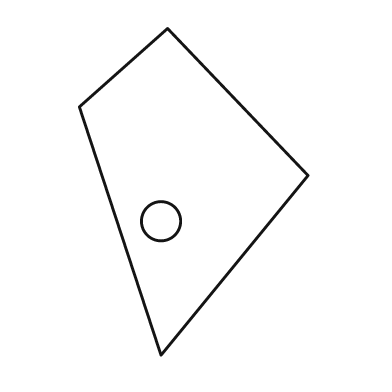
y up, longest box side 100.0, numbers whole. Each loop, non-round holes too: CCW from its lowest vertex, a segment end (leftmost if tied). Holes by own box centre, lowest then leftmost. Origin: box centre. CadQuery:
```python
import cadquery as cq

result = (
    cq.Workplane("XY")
    .moveTo(-10.0, -50.0)
    .lineTo(35.0, 5.0)
    .lineTo(-8.0, 50.0)
    .lineTo(-35.0, 26.0)
    .close()
    .moveTo(-10.0, -9.0)
    .circle(6.0)
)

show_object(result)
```